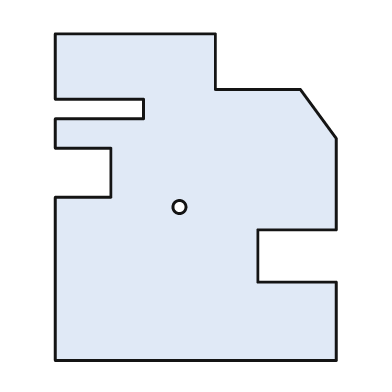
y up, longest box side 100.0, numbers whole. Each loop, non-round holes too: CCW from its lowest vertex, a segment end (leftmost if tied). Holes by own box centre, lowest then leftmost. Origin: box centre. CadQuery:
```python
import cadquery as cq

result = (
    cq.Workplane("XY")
    .moveTo(-43.0, -50.0)
    .lineTo(43.0, -50.0)
    .lineTo(43.0, -26.0)
    .lineTo(19.0, -26.0)
    .lineTo(19.0, -10.0)
    .lineTo(43.0, -10.0)
    .lineTo(43.0, 18.0)
    .lineTo(32.0, 33.0)
    .lineTo(6.0, 33.0)
    .lineTo(6.0, 50.0)
    .lineTo(-43.0, 50.0)
    .lineTo(-43.0, 30.0)
    .lineTo(-16.0, 30.0)
    .lineTo(-16.0, 24.0)
    .lineTo(-43.0, 24.0)
    .lineTo(-43.0, 15.0)
    .lineTo(-26.0, 15.0)
    .lineTo(-26.0, 0.0)
    .lineTo(-43.0, 0.0)
    .close()
    .moveTo(-5.0, -3.0)
    .circle(2.0)
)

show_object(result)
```